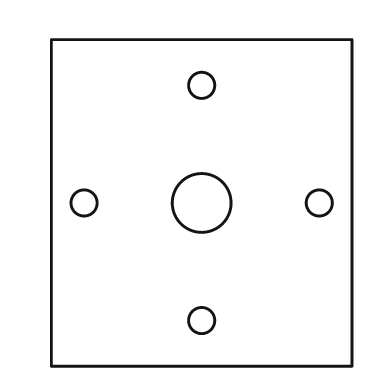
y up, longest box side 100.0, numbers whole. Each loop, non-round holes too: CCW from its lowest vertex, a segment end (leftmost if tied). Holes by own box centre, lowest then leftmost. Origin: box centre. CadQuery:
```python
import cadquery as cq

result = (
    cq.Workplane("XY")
    .moveTo(-46.0, -50.0)
    .lineTo(46.0, -50.0)
    .lineTo(46.0, 50.0)
    .lineTo(-46.0, 50.0)
    .close()
    .moveTo(0.0, -36.0)
    .circle(4.0)
    .moveTo(-36.0, 0.0)
    .circle(4.0)
    .moveTo(0.0, 0.0)
    .circle(9.0)
    .moveTo(36.0, 0.0)
    .circle(4.0)
    .moveTo(0.0, 36.0)
    .circle(4.0)
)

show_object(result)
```